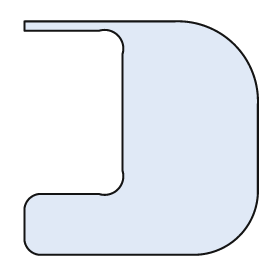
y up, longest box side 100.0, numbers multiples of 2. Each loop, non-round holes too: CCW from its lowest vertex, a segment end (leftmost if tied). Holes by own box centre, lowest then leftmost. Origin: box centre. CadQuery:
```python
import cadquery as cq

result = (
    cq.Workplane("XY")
    .moveTo(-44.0, -50.0)
    .lineTo(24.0, -50.0)
    .threePointArc((42.0, -42.0), (50.0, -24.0))
    .lineTo(50.0, 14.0)
    .threePointArc((40.0, 40.0), (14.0, 50.0))
    .lineTo(-50.0, 50.0)
    .lineTo(-50.0, 46.0)
    .lineTo(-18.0, 46.0)
    .threePointArc((-10.0, 44.0), (-8.0, 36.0))
    .lineTo(-8.0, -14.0)
    .threePointArc((-10.0, -22.0), (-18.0, -24.0))
    .lineTo(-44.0, -24.0)
    .threePointArc((-48.0, -26.0), (-50.0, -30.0))
    .lineTo(-50.0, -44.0)
    .threePointArc((-48.0, -48.0), (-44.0, -50.0))
    .close()
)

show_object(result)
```